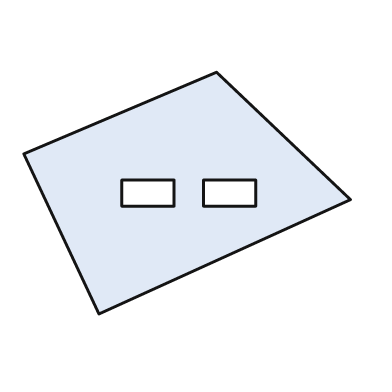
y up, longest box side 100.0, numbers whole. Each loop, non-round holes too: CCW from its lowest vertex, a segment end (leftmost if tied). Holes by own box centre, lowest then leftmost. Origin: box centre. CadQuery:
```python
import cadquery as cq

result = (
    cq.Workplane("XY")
    .moveTo(-27.0, -37.0)
    .lineTo(50.0, -2.0)
    .lineTo(9.0, 37.0)
    .lineTo(-50.0, 12.0)
    .close()
    .moveTo(-20.0, -4.0)
    .lineTo(-4.0, -4.0)
    .lineTo(-4.0, 4.0)
    .lineTo(-20.0, 4.0)
    .close()
    .moveTo(5.0, -4.0)
    .lineTo(21.0, -4.0)
    .lineTo(21.0, 4.0)
    .lineTo(5.0, 4.0)
    .close()
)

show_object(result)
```